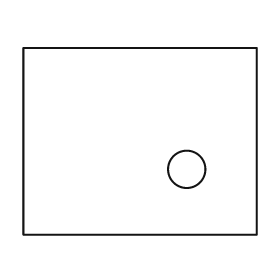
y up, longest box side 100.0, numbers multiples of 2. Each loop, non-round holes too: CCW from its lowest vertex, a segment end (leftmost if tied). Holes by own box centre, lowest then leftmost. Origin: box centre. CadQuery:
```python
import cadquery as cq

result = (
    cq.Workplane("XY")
    .moveTo(-50.0, -40.0)
    .lineTo(50.0, -40.0)
    .lineTo(50.0, 40.0)
    .lineTo(-50.0, 40.0)
    .close()
    .moveTo(20.0, -12.0)
    .circle(8.0)
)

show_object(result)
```